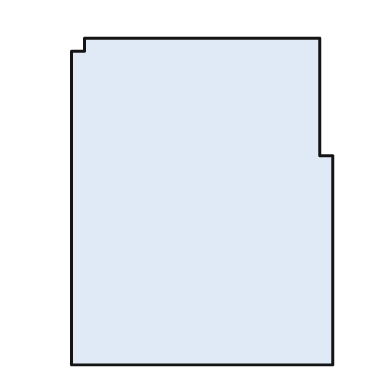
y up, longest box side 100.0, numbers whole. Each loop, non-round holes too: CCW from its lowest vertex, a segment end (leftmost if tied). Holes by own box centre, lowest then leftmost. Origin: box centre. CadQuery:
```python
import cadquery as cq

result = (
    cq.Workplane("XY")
    .moveTo(-40.0, -50.0)
    .lineTo(40.0, -50.0)
    .lineTo(40.0, 14.0)
    .lineTo(36.0, 14.0)
    .lineTo(36.0, 50.0)
    .lineTo(-36.0, 50.0)
    .lineTo(-36.0, 46.0)
    .lineTo(-40.0, 46.0)
    .close()
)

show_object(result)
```